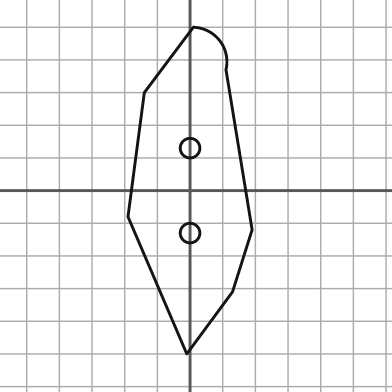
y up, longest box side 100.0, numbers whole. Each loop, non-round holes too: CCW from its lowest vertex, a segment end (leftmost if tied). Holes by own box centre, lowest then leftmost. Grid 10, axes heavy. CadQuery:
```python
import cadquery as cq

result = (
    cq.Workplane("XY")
    .moveTo(-1.0, -50.0)
    .lineTo(13.0, -31.0)
    .lineTo(19.0, -12.0)
    .lineTo(11.0, 37.0)
    .threePointArc((9.0, 46.0), (1.0, 50.0))
    .lineTo(-14.0, 30.0)
    .lineTo(-19.0, -8.0)
    .close()
    .moveTo(0.0, -13.0)
    .circle(3.0)
    .moveTo(0.0, 13.0)
    .circle(3.0)
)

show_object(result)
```